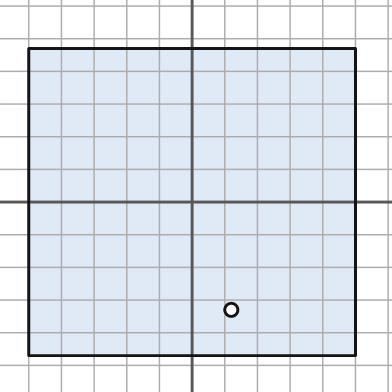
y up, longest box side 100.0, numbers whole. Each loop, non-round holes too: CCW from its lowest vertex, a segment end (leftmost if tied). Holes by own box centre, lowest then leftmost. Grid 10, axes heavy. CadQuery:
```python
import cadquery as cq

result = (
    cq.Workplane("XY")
    .moveTo(-50.0, -47.0)
    .lineTo(50.0, -47.0)
    .lineTo(50.0, 47.0)
    .lineTo(-50.0, 47.0)
    .close()
    .moveTo(12.0, -33.0)
    .circle(2.0)
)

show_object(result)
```